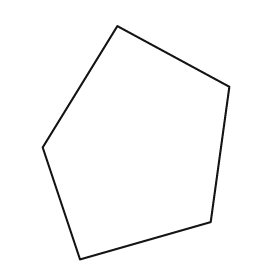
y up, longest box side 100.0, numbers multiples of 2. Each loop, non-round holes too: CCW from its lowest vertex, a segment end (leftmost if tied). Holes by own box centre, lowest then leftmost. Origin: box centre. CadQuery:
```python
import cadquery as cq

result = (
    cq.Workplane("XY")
    .moveTo(-24.0, -50.0)
    .lineTo(32.0, -34.0)
    .lineTo(40.0, 24.0)
    .lineTo(-8.0, 50.0)
    .lineTo(-40.0, -2.0)
    .close()
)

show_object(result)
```